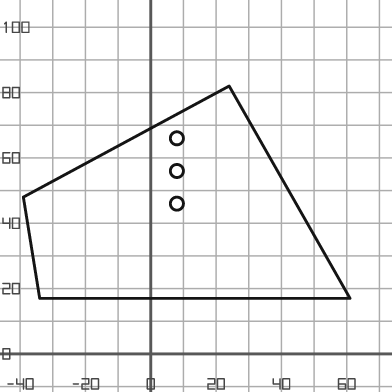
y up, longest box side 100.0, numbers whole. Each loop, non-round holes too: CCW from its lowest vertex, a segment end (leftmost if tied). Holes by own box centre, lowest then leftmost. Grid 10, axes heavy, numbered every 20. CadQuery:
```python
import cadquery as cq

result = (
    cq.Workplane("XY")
    .moveTo(-34.0, 17.0)
    .lineTo(61.0, 17.0)
    .lineTo(24.0, 82.0)
    .lineTo(-39.0, 48.0)
    .close()
    .moveTo(8.0, 46.0)
    .circle(2.0)
    .moveTo(8.0, 56.0)
    .circle(2.0)
    .moveTo(8.0, 66.0)
    .circle(2.0)
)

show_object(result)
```